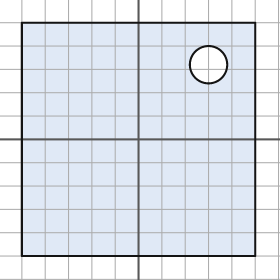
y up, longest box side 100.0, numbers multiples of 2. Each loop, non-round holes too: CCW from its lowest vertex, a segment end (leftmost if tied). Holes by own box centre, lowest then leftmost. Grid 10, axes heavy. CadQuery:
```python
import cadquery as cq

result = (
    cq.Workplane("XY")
    .moveTo(-50.0, -50.0)
    .lineTo(50.0, -50.0)
    .lineTo(50.0, 50.0)
    .lineTo(-50.0, 50.0)
    .close()
    .moveTo(30.0, 32.0)
    .circle(8.0)
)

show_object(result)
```